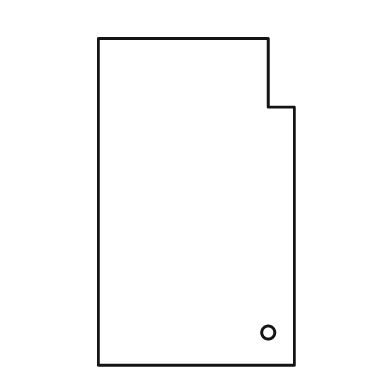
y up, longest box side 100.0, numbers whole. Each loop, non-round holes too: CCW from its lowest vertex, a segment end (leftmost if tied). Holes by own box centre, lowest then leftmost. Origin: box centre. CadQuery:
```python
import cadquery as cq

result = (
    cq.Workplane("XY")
    .moveTo(-30.0, -50.0)
    .lineTo(30.0, -50.0)
    .lineTo(30.0, 29.0)
    .lineTo(22.0, 29.0)
    .lineTo(22.0, 50.0)
    .lineTo(-30.0, 50.0)
    .close()
    .moveTo(22.0, -40.0)
    .circle(2.0)
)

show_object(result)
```